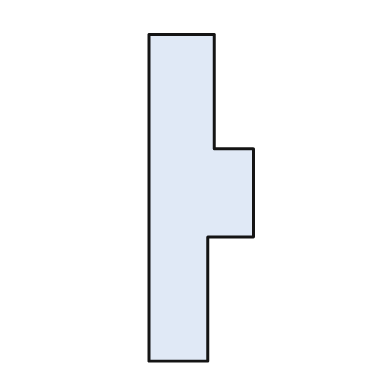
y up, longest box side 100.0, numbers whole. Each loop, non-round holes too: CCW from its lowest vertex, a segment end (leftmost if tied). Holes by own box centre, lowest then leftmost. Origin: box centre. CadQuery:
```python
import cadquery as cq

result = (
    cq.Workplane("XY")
    .moveTo(-16.0, -50.0)
    .lineTo(2.0, -50.0)
    .lineTo(2.0, -12.0)
    .lineTo(16.0, -12.0)
    .lineTo(16.0, 15.0)
    .lineTo(4.0, 15.0)
    .lineTo(4.0, 50.0)
    .lineTo(-16.0, 50.0)
    .close()
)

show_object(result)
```